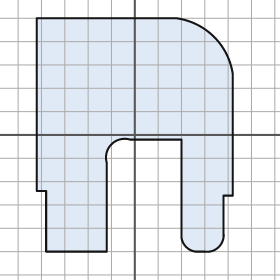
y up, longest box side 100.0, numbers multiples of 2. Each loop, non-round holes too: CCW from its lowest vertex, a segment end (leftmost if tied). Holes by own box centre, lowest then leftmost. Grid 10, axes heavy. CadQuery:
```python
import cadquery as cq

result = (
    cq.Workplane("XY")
    .moveTo(-38.0, -50.0)
    .lineTo(-12.0, -50.0)
    .lineTo(-12.0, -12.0)
    .threePointArc((-10.0, -4.0), (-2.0, -2.0))
    .lineTo(20.0, -2.0)
    .lineTo(20.0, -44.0)
    .threePointArc((22.0, -48.0), (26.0, -50.0))
    .lineTo(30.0, -50.0)
    .threePointArc((36.0, -48.0), (38.0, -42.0))
    .lineTo(38.0, -26.0)
    .lineTo(42.0, -26.0)
    .lineTo(42.0, 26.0)
    .threePointArc((34.0, 42.0), (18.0, 50.0))
    .lineTo(-42.0, 50.0)
    .lineTo(-42.0, -24.0)
    .lineTo(-38.0, -24.0)
    .close()
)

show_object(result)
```